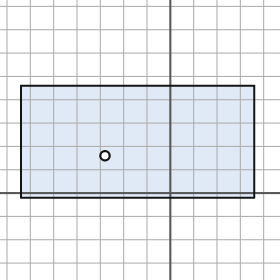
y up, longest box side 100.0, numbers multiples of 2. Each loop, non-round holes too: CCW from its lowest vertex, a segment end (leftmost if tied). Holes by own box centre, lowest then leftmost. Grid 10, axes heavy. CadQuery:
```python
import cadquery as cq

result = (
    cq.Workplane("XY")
    .moveTo(-64.0, -2.0)
    .lineTo(36.0, -2.0)
    .lineTo(36.0, 46.0)
    .lineTo(-64.0, 46.0)
    .close()
    .moveTo(-28.0, 16.0)
    .circle(2.0)
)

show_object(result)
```